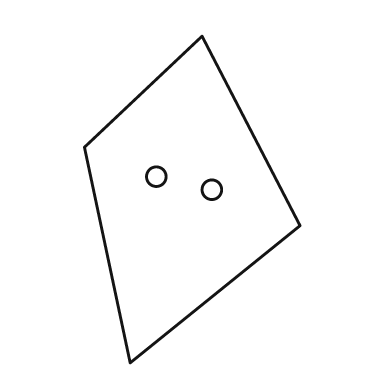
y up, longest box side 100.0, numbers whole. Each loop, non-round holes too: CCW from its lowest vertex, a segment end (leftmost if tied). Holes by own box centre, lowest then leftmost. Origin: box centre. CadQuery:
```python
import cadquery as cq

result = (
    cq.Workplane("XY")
    .moveTo(-19.0, -50.0)
    .lineTo(33.0, -8.0)
    .lineTo(3.0, 50.0)
    .lineTo(-33.0, 16.0)
    .close()
    .moveTo(6.0, 3.0)
    .circle(3.0)
    .moveTo(-11.0, 7.0)
    .circle(3.0)
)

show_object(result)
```